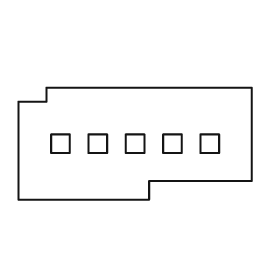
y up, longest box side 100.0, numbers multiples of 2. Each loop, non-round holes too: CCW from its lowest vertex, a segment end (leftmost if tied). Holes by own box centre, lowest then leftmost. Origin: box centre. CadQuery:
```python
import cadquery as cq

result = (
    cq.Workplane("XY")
    .moveTo(-50.0, -24.0)
    .lineTo(6.0, -24.0)
    .lineTo(6.0, -16.0)
    .lineTo(50.0, -16.0)
    .lineTo(50.0, 24.0)
    .lineTo(-38.0, 24.0)
    .lineTo(-38.0, 18.0)
    .lineTo(-50.0, 18.0)
    .close()
    .moveTo(-36.0, -4.0)
    .lineTo(-28.0, -4.0)
    .lineTo(-28.0, 4.0)
    .lineTo(-36.0, 4.0)
    .close()
    .moveTo(-20.0, -4.0)
    .lineTo(-12.0, -4.0)
    .lineTo(-12.0, 4.0)
    .lineTo(-20.0, 4.0)
    .close()
    .moveTo(-4.0, -4.0)
    .lineTo(4.0, -4.0)
    .lineTo(4.0, 4.0)
    .lineTo(-4.0, 4.0)
    .close()
    .moveTo(12.0, -4.0)
    .lineTo(20.0, -4.0)
    .lineTo(20.0, 4.0)
    .lineTo(12.0, 4.0)
    .close()
    .moveTo(28.0, -4.0)
    .lineTo(36.0, -4.0)
    .lineTo(36.0, 4.0)
    .lineTo(28.0, 4.0)
    .close()
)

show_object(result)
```